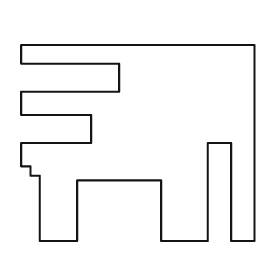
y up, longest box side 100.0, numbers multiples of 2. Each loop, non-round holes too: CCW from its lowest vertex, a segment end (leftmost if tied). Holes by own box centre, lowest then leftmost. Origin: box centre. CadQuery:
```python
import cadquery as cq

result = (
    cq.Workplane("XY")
    .moveTo(-42.0, -42.0)
    .lineTo(-26.0, -42.0)
    .lineTo(-26.0, -16.0)
    .lineTo(10.0, -16.0)
    .lineTo(10.0, -42.0)
    .lineTo(30.0, -42.0)
    .lineTo(30.0, 0.0)
    .lineTo(40.0, 0.0)
    .lineTo(40.0, -42.0)
    .lineTo(50.0, -42.0)
    .lineTo(50.0, 42.0)
    .lineTo(-50.0, 42.0)
    .lineTo(-50.0, 34.0)
    .lineTo(-8.0, 34.0)
    .lineTo(-8.0, 22.0)
    .lineTo(-50.0, 22.0)
    .lineTo(-50.0, 12.0)
    .lineTo(-20.0, 12.0)
    .lineTo(-20.0, 0.0)
    .lineTo(-50.0, 0.0)
    .lineTo(-50.0, -10.0)
    .lineTo(-46.0, -10.0)
    .lineTo(-46.0, -14.0)
    .lineTo(-42.0, -14.0)
    .close()
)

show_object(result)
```